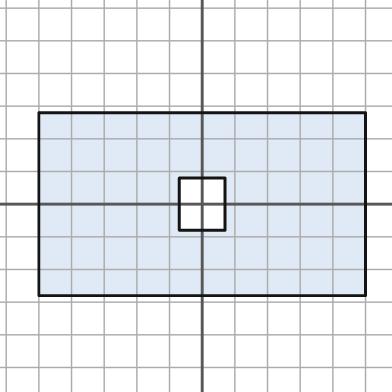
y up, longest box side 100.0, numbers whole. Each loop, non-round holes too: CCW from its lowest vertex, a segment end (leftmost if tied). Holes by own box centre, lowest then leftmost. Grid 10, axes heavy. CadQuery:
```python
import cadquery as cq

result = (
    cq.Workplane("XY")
    .moveTo(-50.0, -28.0)
    .lineTo(50.0, -28.0)
    .lineTo(50.0, 28.0)
    .lineTo(-50.0, 28.0)
    .close()
    .moveTo(-7.0, -8.0)
    .lineTo(7.0, -8.0)
    .lineTo(7.0, 8.0)
    .lineTo(-7.0, 8.0)
    .close()
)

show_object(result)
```